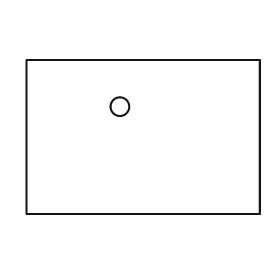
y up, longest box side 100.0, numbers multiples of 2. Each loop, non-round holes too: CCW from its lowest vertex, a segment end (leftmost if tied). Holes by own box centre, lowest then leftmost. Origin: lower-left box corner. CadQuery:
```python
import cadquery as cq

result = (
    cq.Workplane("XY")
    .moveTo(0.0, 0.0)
    .lineTo(100.0, 0.0)
    .lineTo(100.0, 66.0)
    .lineTo(0.0, 66.0)
    .close()
    .moveTo(40.0, 46.0)
    .circle(4.0)
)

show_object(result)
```